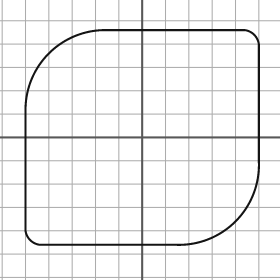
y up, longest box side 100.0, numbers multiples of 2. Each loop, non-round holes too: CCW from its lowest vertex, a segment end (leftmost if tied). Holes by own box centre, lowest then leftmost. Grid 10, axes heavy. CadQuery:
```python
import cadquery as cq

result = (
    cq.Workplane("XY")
    .moveTo(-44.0, -46.0)
    .lineTo(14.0, -46.0)
    .threePointArc((40.0, -36.0), (50.0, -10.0))
    .lineTo(50.0, 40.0)
    .threePointArc((48.0, 44.0), (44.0, 46.0))
    .lineTo(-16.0, 46.0)
    .threePointArc((-40.0, 36.0), (-50.0, 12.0))
    .lineTo(-50.0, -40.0)
    .threePointArc((-48.0, -44.0), (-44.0, -46.0))
    .close()
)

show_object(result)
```